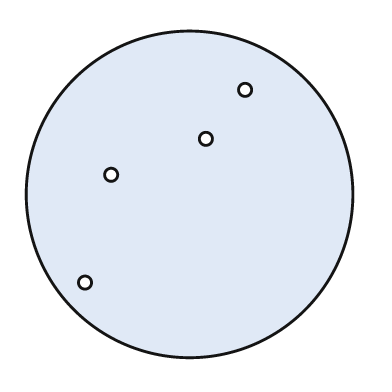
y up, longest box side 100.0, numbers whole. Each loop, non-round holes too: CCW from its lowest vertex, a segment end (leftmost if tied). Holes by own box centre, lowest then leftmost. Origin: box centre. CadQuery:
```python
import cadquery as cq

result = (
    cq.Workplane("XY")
    .moveTo(0.0, 0.0)
    .circle(50.0)
    .moveTo(-32.0, -27.0)
    .circle(2.0)
    .moveTo(-24.0, 6.0)
    .circle(2.0)
    .moveTo(5.0, 17.0)
    .circle(2.0)
    .moveTo(17.0, 32.0)
    .circle(2.0)
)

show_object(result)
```